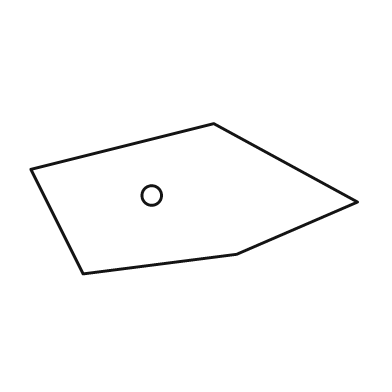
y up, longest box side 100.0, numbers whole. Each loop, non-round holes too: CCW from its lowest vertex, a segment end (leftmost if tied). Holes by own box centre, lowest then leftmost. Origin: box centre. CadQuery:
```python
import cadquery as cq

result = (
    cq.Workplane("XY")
    .moveTo(-34.0, -23.0)
    .lineTo(13.0, -17.0)
    .lineTo(50.0, -1.0)
    .lineTo(6.0, 23.0)
    .lineTo(-50.0, 9.0)
    .close()
    .moveTo(-13.0, 1.0)
    .circle(3.0)
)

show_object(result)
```